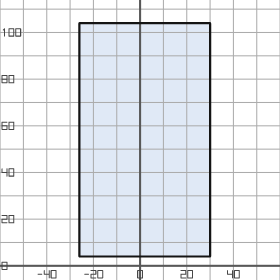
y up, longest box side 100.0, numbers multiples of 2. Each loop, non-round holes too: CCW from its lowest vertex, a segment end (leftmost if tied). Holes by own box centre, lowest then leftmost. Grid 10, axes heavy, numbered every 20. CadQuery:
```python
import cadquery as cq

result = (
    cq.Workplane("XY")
    .moveTo(-26.0, 4.0)
    .lineTo(30.0, 4.0)
    .lineTo(30.0, 104.0)
    .lineTo(-26.0, 104.0)
    .close()
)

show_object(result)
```